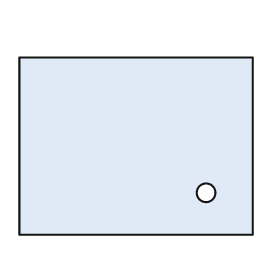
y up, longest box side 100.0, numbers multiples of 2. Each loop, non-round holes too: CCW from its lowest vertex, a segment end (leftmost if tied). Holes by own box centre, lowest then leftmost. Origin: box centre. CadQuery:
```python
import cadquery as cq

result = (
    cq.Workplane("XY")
    .moveTo(-50.0, -38.0)
    .lineTo(50.0, -38.0)
    .lineTo(50.0, 38.0)
    .lineTo(-50.0, 38.0)
    .close()
    .moveTo(30.0, -20.0)
    .circle(4.0)
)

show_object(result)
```